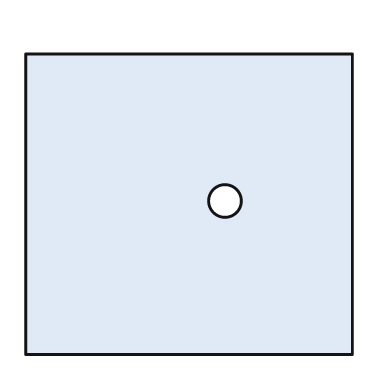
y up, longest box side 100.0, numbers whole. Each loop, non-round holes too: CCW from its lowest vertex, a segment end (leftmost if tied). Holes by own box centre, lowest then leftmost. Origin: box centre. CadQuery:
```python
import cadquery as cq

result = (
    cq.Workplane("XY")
    .moveTo(-50.0, -46.0)
    .lineTo(50.0, -46.0)
    .lineTo(50.0, 46.0)
    .lineTo(-50.0, 46.0)
    .close()
    .moveTo(11.0, 1.0)
    .circle(5.0)
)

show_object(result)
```